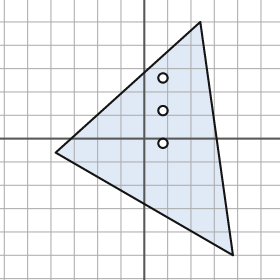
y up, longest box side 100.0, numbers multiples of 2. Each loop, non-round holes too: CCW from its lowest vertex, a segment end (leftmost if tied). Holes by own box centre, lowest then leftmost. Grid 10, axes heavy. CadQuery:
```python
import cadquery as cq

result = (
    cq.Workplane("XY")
    .moveTo(38.0, -50.0)
    .lineTo(24.0, 50.0)
    .lineTo(-38.0, -6.0)
    .close()
    .moveTo(8.0, -2.0)
    .circle(2.0)
    .moveTo(8.0, 12.0)
    .circle(2.0)
    .moveTo(8.0, 26.0)
    .circle(2.0)
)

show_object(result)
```